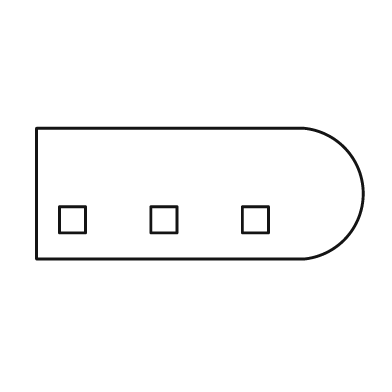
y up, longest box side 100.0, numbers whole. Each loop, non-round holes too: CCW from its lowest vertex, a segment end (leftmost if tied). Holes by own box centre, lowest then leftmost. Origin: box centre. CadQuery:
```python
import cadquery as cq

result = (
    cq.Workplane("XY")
    .moveTo(-50.0, -20.0)
    .lineTo(32.0, -20.0)
    .threePointArc((50.0, 0.0), (32.0, 20.0))
    .lineTo(-50.0, 20.0)
    .close()
    .moveTo(-43.0, -12.0)
    .lineTo(-35.0, -12.0)
    .lineTo(-35.0, -4.0)
    .lineTo(-43.0, -4.0)
    .close()
    .moveTo(-15.0, -12.0)
    .lineTo(-7.0, -12.0)
    .lineTo(-7.0, -4.0)
    .lineTo(-15.0, -4.0)
    .close()
    .moveTo(13.0, -12.0)
    .lineTo(21.0, -12.0)
    .lineTo(21.0, -4.0)
    .lineTo(13.0, -4.0)
    .close()
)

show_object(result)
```